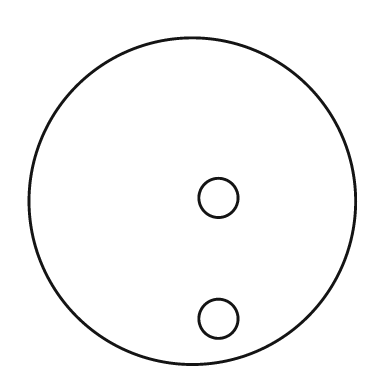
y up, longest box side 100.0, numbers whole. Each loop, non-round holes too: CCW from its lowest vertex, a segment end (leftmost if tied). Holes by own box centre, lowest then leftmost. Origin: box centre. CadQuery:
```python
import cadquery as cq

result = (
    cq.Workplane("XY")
    .moveTo(0.0, 0.0)
    .circle(50.0)
    .moveTo(8.0, -36.0)
    .circle(6.0)
    .moveTo(8.0, 1.0)
    .circle(6.0)
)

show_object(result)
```